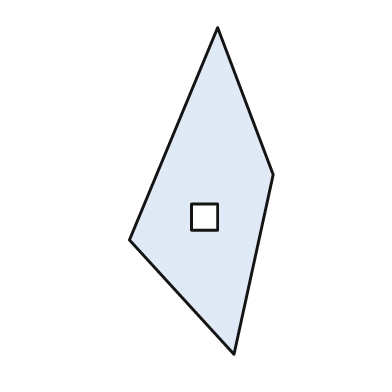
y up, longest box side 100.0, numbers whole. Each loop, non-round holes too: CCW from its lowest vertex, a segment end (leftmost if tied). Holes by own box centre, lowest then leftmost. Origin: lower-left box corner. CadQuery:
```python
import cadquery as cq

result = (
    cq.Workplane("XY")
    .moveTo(32.0, 0.0)
    .lineTo(44.0, 55.0)
    .lineTo(27.0, 100.0)
    .lineTo(0.0, 35.0)
    .close()
    .moveTo(19.0, 38.0)
    .lineTo(27.0, 38.0)
    .lineTo(27.0, 46.0)
    .lineTo(19.0, 46.0)
    .close()
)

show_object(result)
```